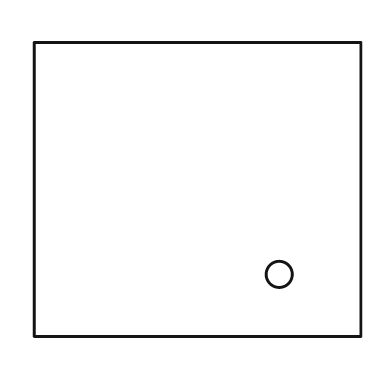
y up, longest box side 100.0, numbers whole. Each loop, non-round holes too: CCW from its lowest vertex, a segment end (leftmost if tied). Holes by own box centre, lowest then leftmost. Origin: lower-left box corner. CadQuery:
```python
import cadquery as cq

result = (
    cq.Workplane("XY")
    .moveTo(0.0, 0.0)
    .lineTo(100.0, 0.0)
    .lineTo(100.0, 90.0)
    .lineTo(0.0, 90.0)
    .close()
    .moveTo(75.0, 19.0)
    .circle(4.0)
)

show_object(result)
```